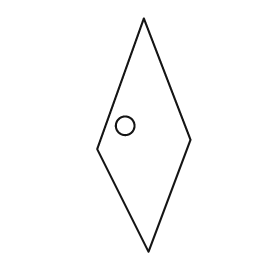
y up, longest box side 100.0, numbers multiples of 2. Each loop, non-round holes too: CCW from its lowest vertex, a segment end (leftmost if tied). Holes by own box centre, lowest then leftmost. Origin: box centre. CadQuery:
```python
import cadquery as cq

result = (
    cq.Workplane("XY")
    .moveTo(2.0, -50.0)
    .lineTo(20.0, -2.0)
    .lineTo(0.0, 50.0)
    .lineTo(-20.0, -6.0)
    .close()
    .moveTo(-8.0, 4.0)
    .circle(4.0)
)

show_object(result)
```